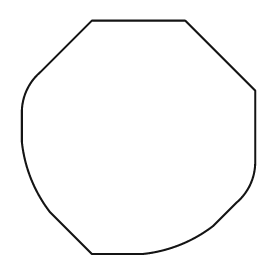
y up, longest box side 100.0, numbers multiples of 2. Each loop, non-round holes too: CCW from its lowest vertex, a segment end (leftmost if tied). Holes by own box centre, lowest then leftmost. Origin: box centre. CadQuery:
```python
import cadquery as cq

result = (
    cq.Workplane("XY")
    .moveTo(-20.0, -50.0)
    .lineTo(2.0, -50.0)
    .threePointArc((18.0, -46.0), (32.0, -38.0))
    .lineTo(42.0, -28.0)
    .threePointArc((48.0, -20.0), (50.0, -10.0))
    .lineTo(50.0, 20.0)
    .lineTo(20.0, 50.0)
    .lineTo(-20.0, 50.0)
    .lineTo(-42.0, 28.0)
    .threePointArc((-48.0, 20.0), (-50.0, 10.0))
    .lineTo(-50.0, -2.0)
    .threePointArc((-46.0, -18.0), (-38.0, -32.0))
    .close()
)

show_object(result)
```